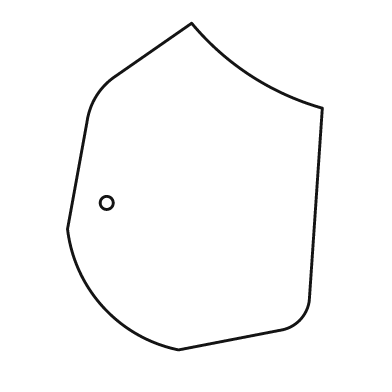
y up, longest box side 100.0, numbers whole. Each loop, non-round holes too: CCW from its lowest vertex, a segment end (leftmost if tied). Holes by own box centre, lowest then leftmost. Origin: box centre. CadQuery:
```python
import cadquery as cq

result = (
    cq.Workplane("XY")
    .moveTo(-5.0, -50.0)
    .lineTo(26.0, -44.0)
    .threePointArc((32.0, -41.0), (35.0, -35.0))
    .lineTo(39.0, 24.0)
    .threePointArc((17.0, 34.0), (-1.0, 50.0))
    .lineTo(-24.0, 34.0)
    .threePointArc((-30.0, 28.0), (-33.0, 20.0))
    .lineTo(-39.0, -13.0)
    .threePointArc((-28.0, -37.0), (-5.0, -50.0))
    .close()
    .moveTo(-27.0, -5.0)
    .circle(2.0)
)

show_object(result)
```